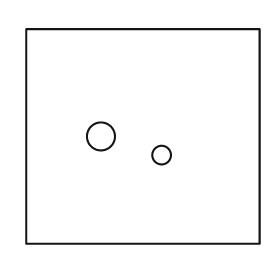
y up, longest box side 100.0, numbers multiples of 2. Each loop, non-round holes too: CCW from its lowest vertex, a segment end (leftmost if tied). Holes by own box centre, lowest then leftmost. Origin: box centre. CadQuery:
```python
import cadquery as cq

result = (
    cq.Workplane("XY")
    .moveTo(-50.0, -46.0)
    .lineTo(50.0, -46.0)
    .lineTo(50.0, 46.0)
    .lineTo(-50.0, 46.0)
    .close()
    .moveTo(8.0, -8.0)
    .circle(4.0)
    .moveTo(-18.0, 0.0)
    .circle(6.0)
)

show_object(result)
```